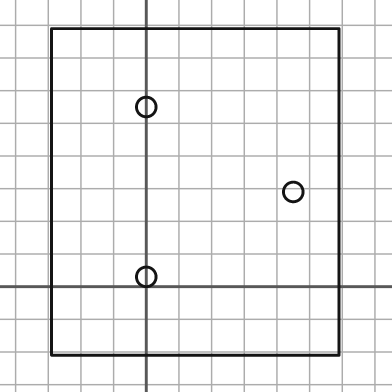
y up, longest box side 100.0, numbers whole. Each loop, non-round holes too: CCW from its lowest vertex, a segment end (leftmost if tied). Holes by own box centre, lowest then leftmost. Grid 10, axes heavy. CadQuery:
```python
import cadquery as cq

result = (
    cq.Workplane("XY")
    .moveTo(-29.0, -21.0)
    .lineTo(59.0, -21.0)
    .lineTo(59.0, 79.0)
    .lineTo(-29.0, 79.0)
    .close()
    .moveTo(0.0, 3.0)
    .circle(3.0)
    .moveTo(45.0, 29.0)
    .circle(3.0)
    .moveTo(0.0, 55.0)
    .circle(3.0)
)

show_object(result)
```